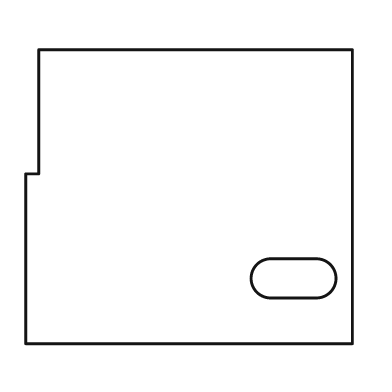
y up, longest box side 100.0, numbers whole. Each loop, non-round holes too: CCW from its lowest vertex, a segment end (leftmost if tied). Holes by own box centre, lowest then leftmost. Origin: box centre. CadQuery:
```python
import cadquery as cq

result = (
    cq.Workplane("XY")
    .moveTo(-50.0, -45.0)
    .lineTo(50.0, -45.0)
    .lineTo(50.0, 45.0)
    .lineTo(-46.0, 45.0)
    .lineTo(-46.0, 7.0)
    .lineTo(-50.0, 7.0)
    .close()
    .moveTo(25.0, -31.0)
    .lineTo(39.0, -31.0)
    .threePointArc((45.0, -25.0), (39.0, -19.0))
    .lineTo(25.0, -19.0)
    .threePointArc((19.0, -25.0), (25.0, -31.0))
    .close()
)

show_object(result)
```